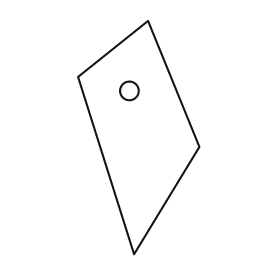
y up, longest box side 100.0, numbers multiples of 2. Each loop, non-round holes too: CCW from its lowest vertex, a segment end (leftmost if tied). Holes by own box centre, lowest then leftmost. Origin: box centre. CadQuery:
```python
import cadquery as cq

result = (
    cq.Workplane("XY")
    .moveTo(-2.0, -50.0)
    .lineTo(26.0, -4.0)
    .lineTo(4.0, 50.0)
    .lineTo(-26.0, 26.0)
    .close()
    .moveTo(-4.0, 20.0)
    .circle(4.0)
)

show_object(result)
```